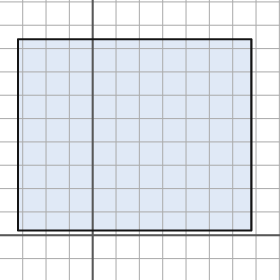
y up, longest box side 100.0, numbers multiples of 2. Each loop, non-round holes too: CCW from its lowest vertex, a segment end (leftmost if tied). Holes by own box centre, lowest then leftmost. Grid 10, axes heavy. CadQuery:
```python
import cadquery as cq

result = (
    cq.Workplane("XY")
    .moveTo(-32.0, 2.0)
    .lineTo(68.0, 2.0)
    .lineTo(68.0, 84.0)
    .lineTo(-32.0, 84.0)
    .close()
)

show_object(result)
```